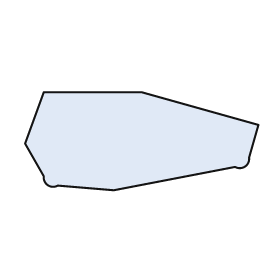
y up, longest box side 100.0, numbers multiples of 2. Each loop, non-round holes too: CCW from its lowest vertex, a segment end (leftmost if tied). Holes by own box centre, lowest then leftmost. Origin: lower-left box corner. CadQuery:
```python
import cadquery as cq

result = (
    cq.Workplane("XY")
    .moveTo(38.0, 0.0)
    .lineTo(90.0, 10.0)
    .threePointArc((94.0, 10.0), (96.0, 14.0))
    .lineTo(100.0, 28.0)
    .lineTo(50.0, 42.0)
    .lineTo(8.0, 42.0)
    .lineTo(0.0, 20.0)
    .lineTo(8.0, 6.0)
    .threePointArc((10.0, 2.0), (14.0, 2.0))
    .close()
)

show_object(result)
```